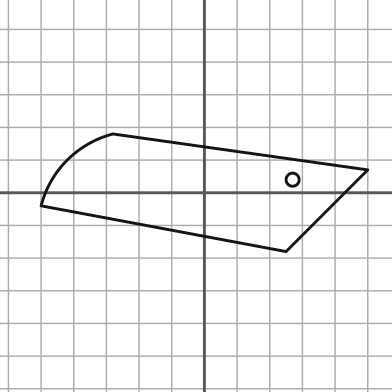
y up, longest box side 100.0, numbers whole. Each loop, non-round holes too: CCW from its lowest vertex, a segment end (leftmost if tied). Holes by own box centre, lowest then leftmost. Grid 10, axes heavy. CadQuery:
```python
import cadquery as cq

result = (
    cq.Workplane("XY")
    .moveTo(25.0, -18.0)
    .lineTo(50.0, 7.0)
    .lineTo(-28.0, 18.0)
    .threePointArc((-42.0, 10.0), (-50.0, -4.0))
    .close()
    .moveTo(27.0, 4.0)
    .circle(2.0)
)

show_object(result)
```